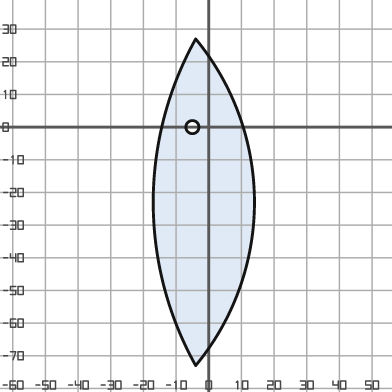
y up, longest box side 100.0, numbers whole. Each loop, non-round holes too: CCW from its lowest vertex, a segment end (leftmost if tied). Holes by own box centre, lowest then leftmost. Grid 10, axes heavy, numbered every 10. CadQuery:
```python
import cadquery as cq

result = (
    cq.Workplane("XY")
    .moveTo(-4.0, -73.0)
    .threePointArc((14.0, -23.0), (-4.0, 27.0))
    .threePointArc((-17.0, -23.0), (-4.0, -73.0))
    .close()
    .moveTo(-5.0, 0.0)
    .circle(2.0)
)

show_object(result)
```